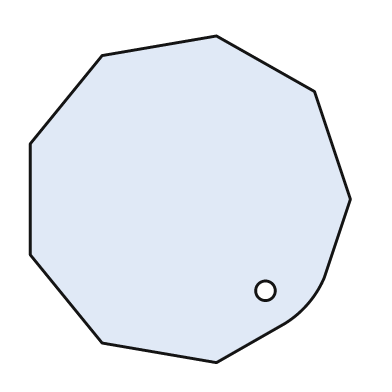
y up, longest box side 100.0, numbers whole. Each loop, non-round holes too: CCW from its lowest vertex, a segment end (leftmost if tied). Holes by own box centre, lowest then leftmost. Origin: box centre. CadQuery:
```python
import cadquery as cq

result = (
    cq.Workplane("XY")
    .moveTo(8.0, -50.0)
    .lineTo(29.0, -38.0)
    .threePointArc((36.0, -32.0), (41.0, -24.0))
    .lineTo(49.0, 0.0)
    .lineTo(38.0, 33.0)
    .lineTo(8.0, 50.0)
    .lineTo(-27.0, 44.0)
    .lineTo(-49.0, 17.0)
    .lineTo(-49.0, -17.0)
    .lineTo(-27.0, -44.0)
    .close()
    .moveTo(23.0, -28.0)
    .circle(3.0)
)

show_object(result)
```